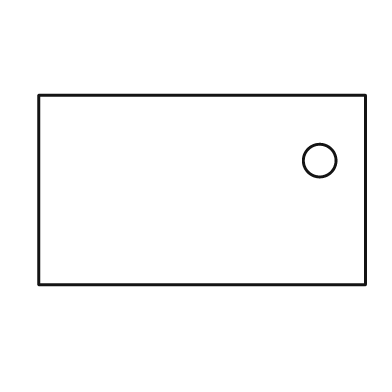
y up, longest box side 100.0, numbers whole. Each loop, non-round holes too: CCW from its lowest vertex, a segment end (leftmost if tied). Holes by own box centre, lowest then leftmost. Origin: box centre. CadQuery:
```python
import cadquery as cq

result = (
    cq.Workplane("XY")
    .moveTo(-50.0, -29.0)
    .lineTo(50.0, -29.0)
    .lineTo(50.0, 29.0)
    .lineTo(-50.0, 29.0)
    .close()
    .moveTo(36.0, 9.0)
    .circle(5.0)
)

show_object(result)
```